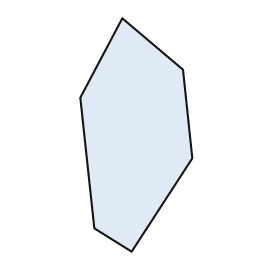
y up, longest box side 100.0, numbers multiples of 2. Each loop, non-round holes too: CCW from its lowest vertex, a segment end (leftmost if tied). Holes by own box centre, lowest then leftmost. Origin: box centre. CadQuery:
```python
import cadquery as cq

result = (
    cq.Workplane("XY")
    .moveTo(-2.0, -50.0)
    .lineTo(24.0, -10.0)
    .lineTo(20.0, 28.0)
    .lineTo(-6.0, 50.0)
    .lineTo(-24.0, 16.0)
    .lineTo(-18.0, -40.0)
    .close()
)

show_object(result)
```